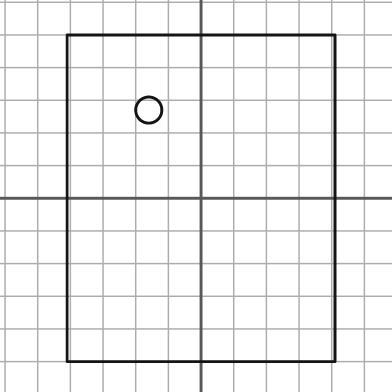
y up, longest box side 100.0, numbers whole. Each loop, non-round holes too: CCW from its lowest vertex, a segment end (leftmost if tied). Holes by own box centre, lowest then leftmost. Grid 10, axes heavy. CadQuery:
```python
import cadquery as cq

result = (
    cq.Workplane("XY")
    .moveTo(-41.0, -50.0)
    .lineTo(41.0, -50.0)
    .lineTo(41.0, 50.0)
    .lineTo(-41.0, 50.0)
    .close()
    .moveTo(-16.0, 27.0)
    .circle(4.0)
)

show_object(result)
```